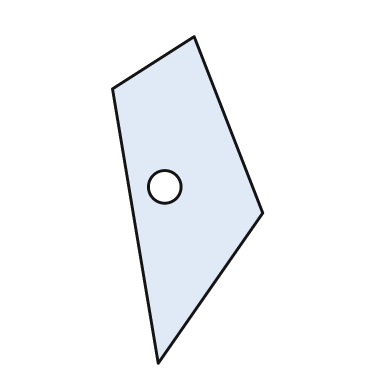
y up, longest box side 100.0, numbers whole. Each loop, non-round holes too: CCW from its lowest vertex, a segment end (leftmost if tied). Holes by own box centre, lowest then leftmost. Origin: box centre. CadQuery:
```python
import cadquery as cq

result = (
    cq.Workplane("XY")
    .moveTo(-9.0, -50.0)
    .lineTo(23.0, -4.0)
    .lineTo(2.0, 50.0)
    .lineTo(-23.0, 34.0)
    .close()
    .moveTo(-7.0, 4.0)
    .circle(5.0)
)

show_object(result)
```